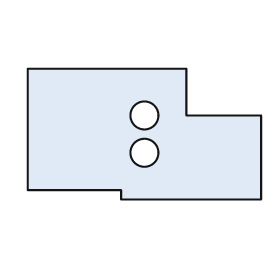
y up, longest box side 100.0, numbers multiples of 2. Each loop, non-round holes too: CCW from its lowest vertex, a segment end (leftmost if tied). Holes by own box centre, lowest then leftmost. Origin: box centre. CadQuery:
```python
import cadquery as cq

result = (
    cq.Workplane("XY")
    .moveTo(-10.0, -28.0)
    .lineTo(50.0, -28.0)
    .lineTo(50.0, 8.0)
    .lineTo(18.0, 8.0)
    .lineTo(18.0, 28.0)
    .lineTo(-50.0, 28.0)
    .lineTo(-50.0, -24.0)
    .lineTo(-10.0, -24.0)
    .close()
    .moveTo(0.0, -8.0)
    .circle(6.0)
    .moveTo(0.0, 8.0)
    .circle(6.0)
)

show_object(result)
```